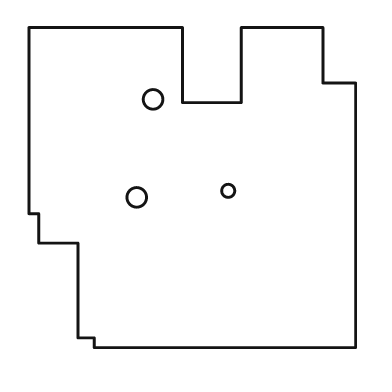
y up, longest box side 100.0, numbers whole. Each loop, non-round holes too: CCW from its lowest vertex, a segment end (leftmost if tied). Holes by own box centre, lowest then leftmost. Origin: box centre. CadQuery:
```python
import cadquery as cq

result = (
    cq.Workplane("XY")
    .moveTo(-30.0, -49.0)
    .lineTo(50.0, -49.0)
    .lineTo(50.0, 32.0)
    .lineTo(40.0, 32.0)
    .lineTo(40.0, 49.0)
    .lineTo(15.0, 49.0)
    .lineTo(15.0, 26.0)
    .lineTo(-3.0, 26.0)
    .lineTo(-3.0, 49.0)
    .lineTo(-50.0, 49.0)
    .lineTo(-50.0, -8.0)
    .lineTo(-47.0, -8.0)
    .lineTo(-47.0, -17.0)
    .lineTo(-35.0, -17.0)
    .lineTo(-35.0, -46.0)
    .lineTo(-30.0, -46.0)
    .close()
    .moveTo(-17.0, -3.0)
    .circle(3.0)
    .moveTo(11.0, -1.0)
    .circle(2.0)
    .moveTo(-12.0, 27.0)
    .circle(3.0)
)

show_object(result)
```